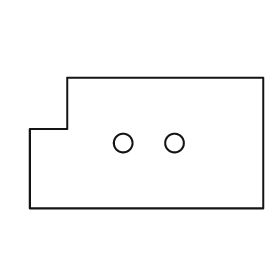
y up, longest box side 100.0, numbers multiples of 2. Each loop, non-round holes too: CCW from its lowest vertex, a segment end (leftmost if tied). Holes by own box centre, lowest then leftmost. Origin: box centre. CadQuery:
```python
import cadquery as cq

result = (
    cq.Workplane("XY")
    .moveTo(-50.0, -28.0)
    .lineTo(50.0, -28.0)
    .lineTo(50.0, 28.0)
    .lineTo(-34.0, 28.0)
    .lineTo(-34.0, 6.0)
    .lineTo(-50.0, 6.0)
    .close()
    .moveTo(-10.0, 0.0)
    .circle(4.0)
    .moveTo(12.0, 0.0)
    .circle(4.0)
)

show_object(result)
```